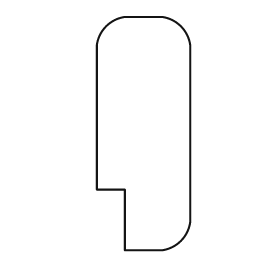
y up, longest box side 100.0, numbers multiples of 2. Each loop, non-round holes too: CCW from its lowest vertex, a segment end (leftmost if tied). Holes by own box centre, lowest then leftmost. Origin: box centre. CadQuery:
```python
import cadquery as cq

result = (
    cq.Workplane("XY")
    .moveTo(-8.0, -50.0)
    .lineTo(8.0, -50.0)
    .threePointArc((16.0, -46.0), (20.0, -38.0))
    .lineTo(20.0, 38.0)
    .threePointArc((16.0, 46.0), (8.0, 50.0))
    .lineTo(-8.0, 50.0)
    .threePointArc((-16.0, 46.0), (-20.0, 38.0))
    .lineTo(-20.0, -24.0)
    .lineTo(-8.0, -24.0)
    .close()
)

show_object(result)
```